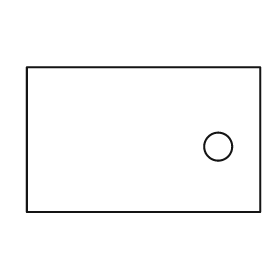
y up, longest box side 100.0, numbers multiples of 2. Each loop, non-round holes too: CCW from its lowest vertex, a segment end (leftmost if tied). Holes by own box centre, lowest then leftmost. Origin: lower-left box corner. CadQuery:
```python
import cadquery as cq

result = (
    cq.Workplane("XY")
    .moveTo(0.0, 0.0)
    .lineTo(100.0, 0.0)
    .lineTo(100.0, 62.0)
    .lineTo(0.0, 62.0)
    .close()
    .moveTo(82.0, 28.0)
    .circle(6.0)
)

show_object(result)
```